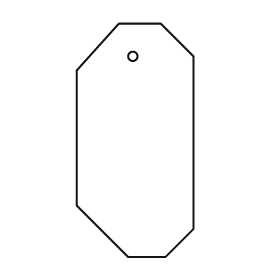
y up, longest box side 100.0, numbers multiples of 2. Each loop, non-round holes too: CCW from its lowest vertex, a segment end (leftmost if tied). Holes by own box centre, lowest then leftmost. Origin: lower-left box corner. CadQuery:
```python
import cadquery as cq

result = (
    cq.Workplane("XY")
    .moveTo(22.0, 0.0)
    .lineTo(38.0, 0.0)
    .lineTo(50.0, 12.0)
    .lineTo(50.0, 86.0)
    .lineTo(36.0, 100.0)
    .lineTo(18.0, 100.0)
    .lineTo(0.0, 80.0)
    .lineTo(0.0, 22.0)
    .close()
    .moveTo(24.0, 86.0)
    .circle(2.0)
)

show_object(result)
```